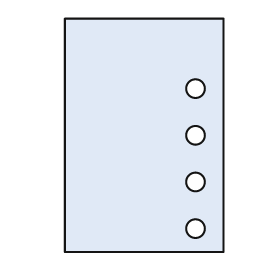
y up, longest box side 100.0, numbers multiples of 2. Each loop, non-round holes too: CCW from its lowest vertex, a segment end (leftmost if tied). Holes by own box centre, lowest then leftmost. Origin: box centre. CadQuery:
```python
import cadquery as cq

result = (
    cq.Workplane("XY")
    .moveTo(-34.0, -50.0)
    .lineTo(34.0, -50.0)
    .lineTo(34.0, 50.0)
    .lineTo(-34.0, 50.0)
    .close()
    .moveTo(22.0, -40.0)
    .circle(4.0)
    .moveTo(22.0, -20.0)
    .circle(4.0)
    .moveTo(22.0, 0.0)
    .circle(4.0)
    .moveTo(22.0, 20.0)
    .circle(4.0)
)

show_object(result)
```